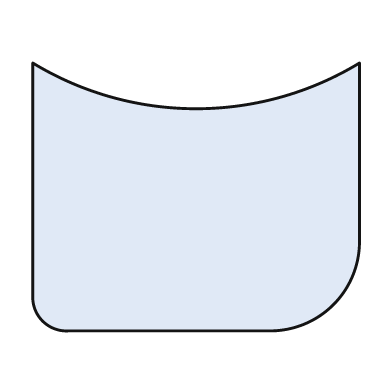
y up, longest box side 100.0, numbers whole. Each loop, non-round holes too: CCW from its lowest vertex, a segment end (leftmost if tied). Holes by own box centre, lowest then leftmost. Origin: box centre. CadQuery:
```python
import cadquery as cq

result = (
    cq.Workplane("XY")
    .moveTo(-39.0, -41.0)
    .lineTo(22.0, -41.0)
    .threePointArc((42.0, -33.0), (50.0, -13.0))
    .lineTo(50.0, 41.0)
    .threePointArc((0.0, 27.0), (-50.0, 41.0))
    .lineTo(-50.0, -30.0)
    .threePointArc((-47.0, -38.0), (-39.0, -41.0))
    .close()
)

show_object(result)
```